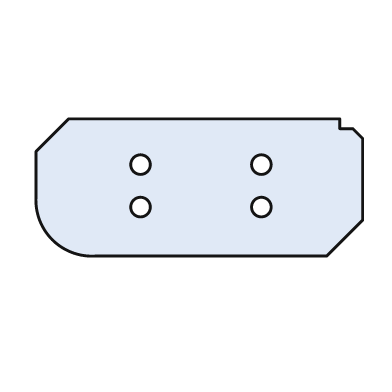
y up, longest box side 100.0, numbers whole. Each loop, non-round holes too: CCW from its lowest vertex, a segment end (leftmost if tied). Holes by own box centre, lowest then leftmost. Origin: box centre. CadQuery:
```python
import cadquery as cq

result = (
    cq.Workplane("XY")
    .moveTo(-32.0, -21.0)
    .lineTo(39.0, -21.0)
    .lineTo(50.0, -10.0)
    .lineTo(50.0, 15.0)
    .lineTo(47.0, 18.0)
    .lineTo(43.0, 18.0)
    .lineTo(43.0, 21.0)
    .lineTo(-40.0, 21.0)
    .lineTo(-50.0, 11.0)
    .lineTo(-50.0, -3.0)
    .threePointArc((-45.0, -16.0), (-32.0, -21.0))
    .close()
    .moveTo(-18.0, -6.0)
    .circle(3.0)
    .moveTo(19.0, -6.0)
    .circle(3.0)
    .moveTo(-18.0, 7.0)
    .circle(3.0)
    .moveTo(19.0, 7.0)
    .circle(3.0)
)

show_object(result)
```